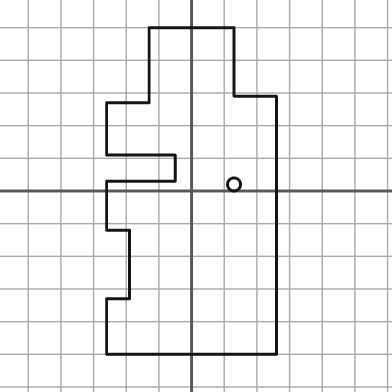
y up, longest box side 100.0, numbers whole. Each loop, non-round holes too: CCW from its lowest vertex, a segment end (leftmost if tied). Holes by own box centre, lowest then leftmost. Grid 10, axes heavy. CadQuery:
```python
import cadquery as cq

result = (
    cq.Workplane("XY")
    .moveTo(-26.0, -50.0)
    .lineTo(26.0, -50.0)
    .lineTo(26.0, 29.0)
    .lineTo(13.0, 29.0)
    .lineTo(13.0, 50.0)
    .lineTo(-13.0, 50.0)
    .lineTo(-13.0, 27.0)
    .lineTo(-26.0, 27.0)
    .lineTo(-26.0, 11.0)
    .lineTo(-5.0, 11.0)
    .lineTo(-5.0, 3.0)
    .lineTo(-26.0, 3.0)
    .lineTo(-26.0, -12.0)
    .lineTo(-19.0, -12.0)
    .lineTo(-19.0, -33.0)
    .lineTo(-26.0, -33.0)
    .close()
    .moveTo(13.0, 2.0)
    .circle(2.0)
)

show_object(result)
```